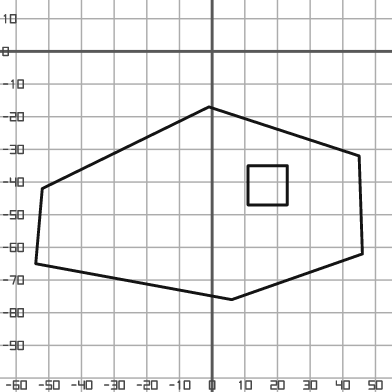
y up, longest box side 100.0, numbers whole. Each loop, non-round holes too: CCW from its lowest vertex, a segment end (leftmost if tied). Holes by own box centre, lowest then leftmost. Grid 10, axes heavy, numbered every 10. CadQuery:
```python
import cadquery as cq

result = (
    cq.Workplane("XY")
    .moveTo(6.0, -76.0)
    .lineTo(46.0, -62.0)
    .lineTo(45.0, -32.0)
    .lineTo(-1.0, -17.0)
    .lineTo(-52.0, -42.0)
    .lineTo(-54.0, -65.0)
    .close()
    .moveTo(11.0, -47.0)
    .lineTo(23.0, -47.0)
    .lineTo(23.0, -35.0)
    .lineTo(11.0, -35.0)
    .close()
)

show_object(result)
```